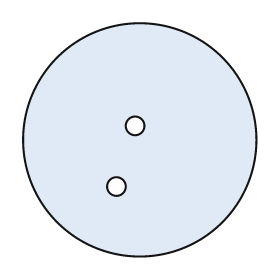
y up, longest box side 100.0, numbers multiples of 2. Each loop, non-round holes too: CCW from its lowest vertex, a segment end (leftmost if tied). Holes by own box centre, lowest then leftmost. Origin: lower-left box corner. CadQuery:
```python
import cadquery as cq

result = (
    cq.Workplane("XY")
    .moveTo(50.0, 50.0)
    .circle(50.0)
    .moveTo(40.0, 30.0)
    .circle(4.0)
    .moveTo(48.0, 56.0)
    .circle(4.0)
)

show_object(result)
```